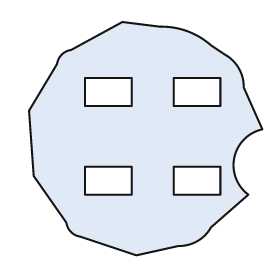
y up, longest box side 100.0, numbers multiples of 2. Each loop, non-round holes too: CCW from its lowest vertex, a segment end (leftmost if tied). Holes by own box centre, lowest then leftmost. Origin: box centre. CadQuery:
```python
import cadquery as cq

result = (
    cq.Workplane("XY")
    .moveTo(-4.0, -50.0)
    .lineTo(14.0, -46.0)
    .threePointArc((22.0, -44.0), (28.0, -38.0))
    .lineTo(44.0, -24.0)
    .threePointArc((38.0, -8.0), (50.0, 4.0))
    .lineTo(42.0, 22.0)
    .threePointArc((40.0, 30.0), (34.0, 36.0))
    .lineTo(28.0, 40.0)
    .threePointArc((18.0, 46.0), (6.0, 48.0))
    .lineTo(-10.0, 50.0)
    .lineTo(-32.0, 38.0)
    .threePointArc((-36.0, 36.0), (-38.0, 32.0))
    .lineTo(-50.0, 12.0)
    .lineTo(-48.0, -16.0)
    .lineTo(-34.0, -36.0)
    .threePointArc((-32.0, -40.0), (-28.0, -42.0))
    .close()
    .moveTo(-26.0, -24.0)
    .lineTo(-6.0, -24.0)
    .lineTo(-6.0, -12.0)
    .lineTo(-26.0, -12.0)
    .close()
    .moveTo(12.0, -24.0)
    .lineTo(32.0, -24.0)
    .lineTo(32.0, -12.0)
    .lineTo(12.0, -12.0)
    .close()
    .moveTo(-26.0, 14.0)
    .lineTo(-6.0, 14.0)
    .lineTo(-6.0, 26.0)
    .lineTo(-26.0, 26.0)
    .close()
    .moveTo(12.0, 14.0)
    .lineTo(32.0, 14.0)
    .lineTo(32.0, 26.0)
    .lineTo(12.0, 26.0)
    .close()
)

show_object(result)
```